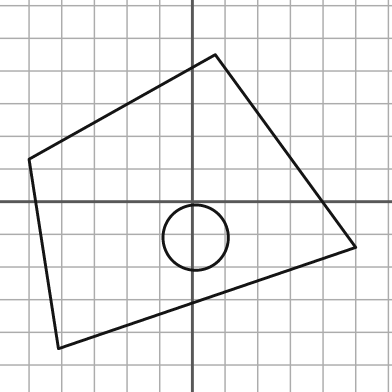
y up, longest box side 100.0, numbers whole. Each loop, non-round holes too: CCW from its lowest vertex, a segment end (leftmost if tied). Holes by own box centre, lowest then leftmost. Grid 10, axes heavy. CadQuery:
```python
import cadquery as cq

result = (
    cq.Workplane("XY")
    .moveTo(-41.0, -45.0)
    .lineTo(50.0, -14.0)
    .lineTo(7.0, 45.0)
    .lineTo(-50.0, 13.0)
    .close()
    .moveTo(1.0, -11.0)
    .circle(10.0)
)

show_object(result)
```